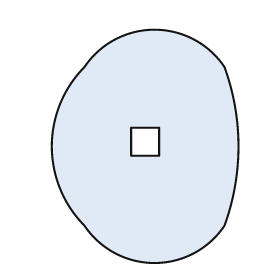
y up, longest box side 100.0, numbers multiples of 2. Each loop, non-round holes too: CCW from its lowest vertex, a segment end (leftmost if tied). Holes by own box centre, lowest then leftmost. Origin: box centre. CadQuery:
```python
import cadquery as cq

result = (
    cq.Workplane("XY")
    .moveTo(-26.0, -34.0)
    .threePointArc((4.0, -50.0), (34.0, -34.0))
    .threePointArc((40.0, 0.0), (34.0, 34.0))
    .threePointArc((4.0, 50.0), (-26.0, 34.0))
    .threePointArc((-40.0, 0.0), (-26.0, -34.0))
    .close()
    .moveTo(-6.0, -4.0)
    .lineTo(6.0, -4.0)
    .lineTo(6.0, 8.0)
    .lineTo(-6.0, 8.0)
    .close()
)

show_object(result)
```